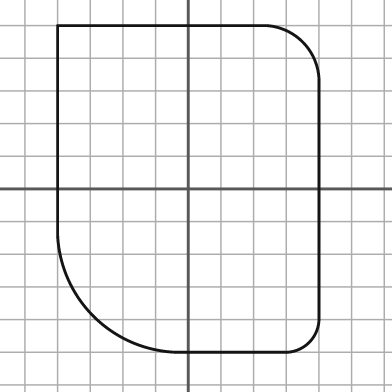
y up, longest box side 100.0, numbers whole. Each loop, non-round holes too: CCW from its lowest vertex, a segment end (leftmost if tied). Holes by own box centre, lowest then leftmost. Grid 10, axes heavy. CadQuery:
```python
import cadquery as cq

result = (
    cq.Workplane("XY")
    .moveTo(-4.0, -50.0)
    .lineTo(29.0, -50.0)
    .threePointArc((37.0, -47.0), (40.0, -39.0))
    .lineTo(40.0, 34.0)
    .threePointArc((35.0, 45.0), (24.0, 50.0))
    .lineTo(-40.0, 50.0)
    .lineTo(-40.0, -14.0)
    .threePointArc((-29.0, -39.0), (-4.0, -50.0))
    .close()
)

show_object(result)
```